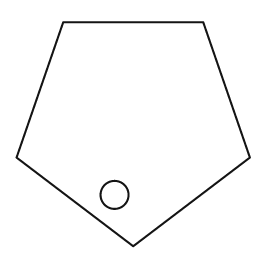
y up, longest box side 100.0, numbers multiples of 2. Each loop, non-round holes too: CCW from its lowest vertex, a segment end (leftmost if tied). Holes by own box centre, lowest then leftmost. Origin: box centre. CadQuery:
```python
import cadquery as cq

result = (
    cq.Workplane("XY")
    .moveTo(0.0, -48.0)
    .lineTo(50.0, -10.0)
    .lineTo(30.0, 48.0)
    .lineTo(-30.0, 48.0)
    .lineTo(-50.0, -10.0)
    .close()
    .moveTo(-8.0, -26.0)
    .circle(6.0)
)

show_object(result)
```